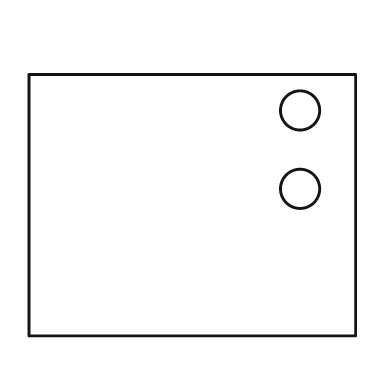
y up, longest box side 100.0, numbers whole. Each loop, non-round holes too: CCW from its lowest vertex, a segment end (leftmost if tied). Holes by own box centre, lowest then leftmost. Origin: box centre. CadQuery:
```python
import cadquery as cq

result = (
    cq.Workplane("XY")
    .moveTo(-50.0, -40.0)
    .lineTo(50.0, -40.0)
    .lineTo(50.0, 40.0)
    .lineTo(-50.0, 40.0)
    .close()
    .moveTo(33.0, 5.0)
    .circle(6.0)
    .moveTo(33.0, 29.0)
    .circle(6.0)
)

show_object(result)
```